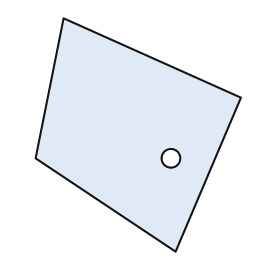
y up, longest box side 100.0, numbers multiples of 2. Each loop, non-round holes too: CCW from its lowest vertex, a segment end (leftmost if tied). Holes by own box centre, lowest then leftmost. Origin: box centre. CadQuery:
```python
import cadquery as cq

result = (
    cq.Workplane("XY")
    .moveTo(16.0, -50.0)
    .lineTo(44.0, 16.0)
    .lineTo(-32.0, 50.0)
    .lineTo(-44.0, -10.0)
    .close()
    .moveTo(14.0, -10.0)
    .circle(4.0)
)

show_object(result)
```